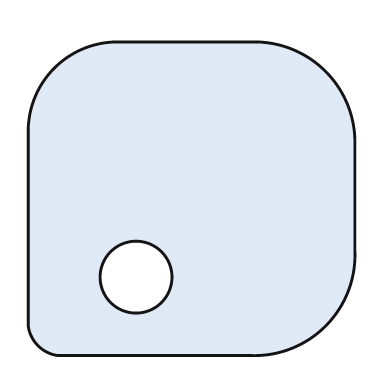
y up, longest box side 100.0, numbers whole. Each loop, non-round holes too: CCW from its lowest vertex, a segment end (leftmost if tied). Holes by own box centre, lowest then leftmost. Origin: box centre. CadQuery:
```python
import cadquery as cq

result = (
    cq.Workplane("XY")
    .moveTo(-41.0, -48.0)
    .lineTo(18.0, -48.0)
    .threePointArc((41.0, -39.0), (50.0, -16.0))
    .lineTo(50.0, 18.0)
    .threePointArc((41.0, 39.0), (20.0, 48.0))
    .lineTo(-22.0, 48.0)
    .threePointArc((-42.0, 40.0), (-50.0, 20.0))
    .lineTo(-50.0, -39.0)
    .threePointArc((-47.0, -45.0), (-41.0, -48.0))
    .close()
    .moveTo(-17.0, -24.0)
    .circle(11.0)
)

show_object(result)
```